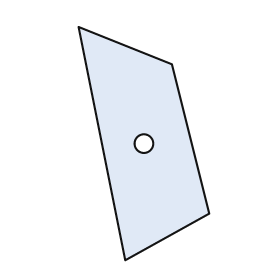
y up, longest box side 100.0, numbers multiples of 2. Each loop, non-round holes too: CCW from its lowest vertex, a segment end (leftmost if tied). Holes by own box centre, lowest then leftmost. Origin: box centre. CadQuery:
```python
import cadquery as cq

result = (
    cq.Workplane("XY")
    .moveTo(-8.0, -50.0)
    .lineTo(28.0, -30.0)
    .lineTo(12.0, 34.0)
    .lineTo(-28.0, 50.0)
    .close()
    .moveTo(0.0, 0.0)
    .circle(4.0)
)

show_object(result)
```